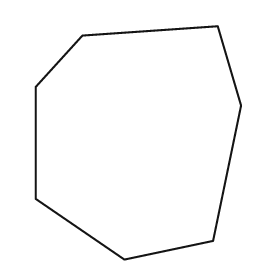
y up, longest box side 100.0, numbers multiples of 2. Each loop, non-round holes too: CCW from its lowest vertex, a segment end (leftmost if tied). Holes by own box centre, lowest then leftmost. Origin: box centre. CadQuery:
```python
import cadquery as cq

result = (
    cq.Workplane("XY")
    .moveTo(-6.0, -50.0)
    .lineTo(32.0, -42.0)
    .lineTo(44.0, 16.0)
    .lineTo(34.0, 50.0)
    .lineTo(-24.0, 46.0)
    .lineTo(-44.0, 24.0)
    .lineTo(-44.0, -24.0)
    .close()
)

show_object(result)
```